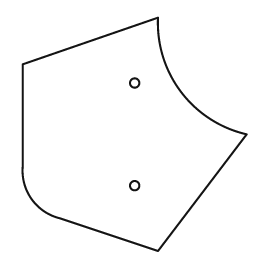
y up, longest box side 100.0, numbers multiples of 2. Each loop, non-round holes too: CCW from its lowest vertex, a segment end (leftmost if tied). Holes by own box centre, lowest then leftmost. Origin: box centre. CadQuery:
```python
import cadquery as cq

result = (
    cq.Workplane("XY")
    .moveTo(10.0, -50.0)
    .lineTo(48.0, 0.0)
    .threePointArc((20.0, 18.0), (10.0, 50.0))
    .lineTo(-48.0, 30.0)
    .lineTo(-48.0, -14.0)
    .threePointArc((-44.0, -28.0), (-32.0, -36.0))
    .close()
    .moveTo(0.0, -22.0)
    .circle(2.0)
    .moveTo(0.0, 22.0)
    .circle(2.0)
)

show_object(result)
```